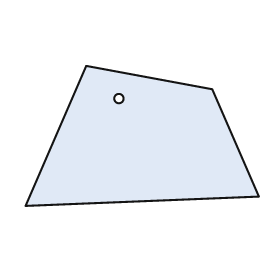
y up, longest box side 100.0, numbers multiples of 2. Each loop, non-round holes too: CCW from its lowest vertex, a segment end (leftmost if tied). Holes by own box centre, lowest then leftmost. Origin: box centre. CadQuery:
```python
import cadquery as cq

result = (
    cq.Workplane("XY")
    .moveTo(-50.0, -30.0)
    .lineTo(50.0, -26.0)
    .lineTo(30.0, 20.0)
    .lineTo(-24.0, 30.0)
    .close()
    .moveTo(-10.0, 16.0)
    .circle(2.0)
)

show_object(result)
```